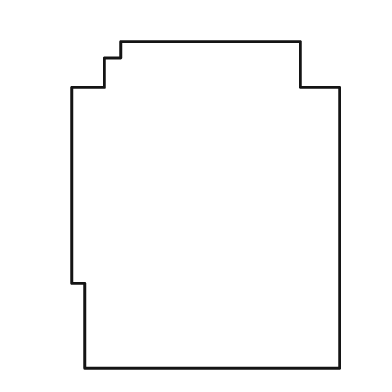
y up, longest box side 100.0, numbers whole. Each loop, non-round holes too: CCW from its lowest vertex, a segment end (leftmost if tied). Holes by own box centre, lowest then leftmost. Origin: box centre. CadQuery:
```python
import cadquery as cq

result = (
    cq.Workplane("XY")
    .moveTo(-37.0, -50.0)
    .lineTo(41.0, -50.0)
    .lineTo(41.0, 36.0)
    .lineTo(29.0, 36.0)
    .lineTo(29.0, 50.0)
    .lineTo(-26.0, 50.0)
    .lineTo(-26.0, 45.0)
    .lineTo(-31.0, 45.0)
    .lineTo(-31.0, 36.0)
    .lineTo(-41.0, 36.0)
    .lineTo(-41.0, -24.0)
    .lineTo(-37.0, -24.0)
    .close()
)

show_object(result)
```